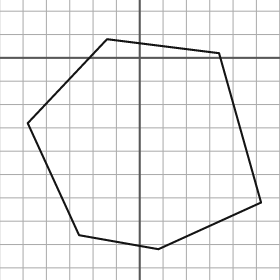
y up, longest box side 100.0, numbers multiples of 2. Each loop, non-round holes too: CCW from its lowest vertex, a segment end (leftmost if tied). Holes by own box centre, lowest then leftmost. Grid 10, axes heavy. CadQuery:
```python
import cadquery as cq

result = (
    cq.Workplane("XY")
    .moveTo(8.0, -82.0)
    .lineTo(52.0, -62.0)
    .lineTo(34.0, 2.0)
    .lineTo(-14.0, 8.0)
    .lineTo(-48.0, -28.0)
    .lineTo(-26.0, -76.0)
    .close()
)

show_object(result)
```